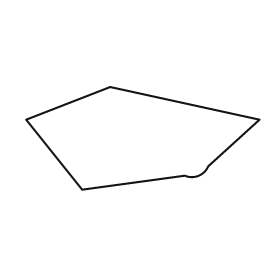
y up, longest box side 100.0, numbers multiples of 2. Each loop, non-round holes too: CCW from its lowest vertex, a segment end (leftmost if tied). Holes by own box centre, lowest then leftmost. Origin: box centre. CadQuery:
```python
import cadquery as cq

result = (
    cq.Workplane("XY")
    .moveTo(-26.0, -22.0)
    .lineTo(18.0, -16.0)
    .threePointArc((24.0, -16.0), (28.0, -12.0))
    .lineTo(50.0, 8.0)
    .lineTo(-14.0, 22.0)
    .lineTo(-50.0, 8.0)
    .close()
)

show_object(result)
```